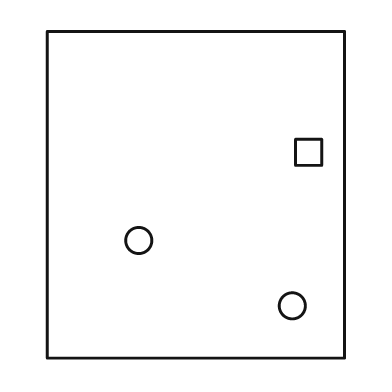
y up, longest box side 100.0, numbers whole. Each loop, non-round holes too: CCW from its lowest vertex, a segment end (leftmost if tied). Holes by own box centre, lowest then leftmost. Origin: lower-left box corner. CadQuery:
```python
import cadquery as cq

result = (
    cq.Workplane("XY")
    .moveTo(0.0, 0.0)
    .lineTo(91.0, 0.0)
    .lineTo(91.0, 100.0)
    .lineTo(0.0, 100.0)
    .close()
    .moveTo(75.0, 16.0)
    .circle(4.0)
    .moveTo(28.0, 36.0)
    .circle(4.0)
    .moveTo(76.0, 59.0)
    .lineTo(84.0, 59.0)
    .lineTo(84.0, 67.0)
    .lineTo(76.0, 67.0)
    .close()
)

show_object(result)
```